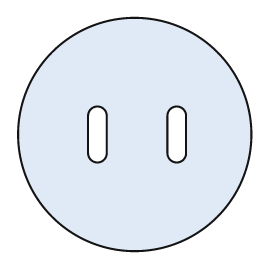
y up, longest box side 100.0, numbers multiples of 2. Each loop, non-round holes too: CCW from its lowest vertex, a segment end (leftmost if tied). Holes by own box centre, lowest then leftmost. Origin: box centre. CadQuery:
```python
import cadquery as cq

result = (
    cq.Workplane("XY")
    .moveTo(0.0, 0.0)
    .circle(50.0)
    .moveTo(-20.0, -8.0)
    .threePointArc((-16.0, -12.0), (-12.0, -8.0))
    .lineTo(-12.0, 8.0)
    .threePointArc((-16.0, 12.0), (-20.0, 8.0))
    .close()
    .moveTo(14.0, -8.0)
    .threePointArc((18.0, -12.0), (22.0, -8.0))
    .lineTo(22.0, 8.0)
    .threePointArc((18.0, 12.0), (14.0, 8.0))
    .close()
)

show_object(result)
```